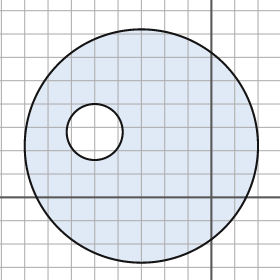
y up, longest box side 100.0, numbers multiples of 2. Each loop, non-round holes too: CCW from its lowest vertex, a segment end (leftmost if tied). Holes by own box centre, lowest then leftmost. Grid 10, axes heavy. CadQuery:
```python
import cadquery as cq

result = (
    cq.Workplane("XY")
    .moveTo(-30.0, 22.0)
    .circle(50.0)
    .moveTo(-50.0, 28.0)
    .circle(12.0)
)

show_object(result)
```